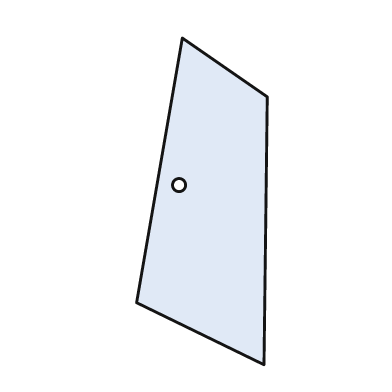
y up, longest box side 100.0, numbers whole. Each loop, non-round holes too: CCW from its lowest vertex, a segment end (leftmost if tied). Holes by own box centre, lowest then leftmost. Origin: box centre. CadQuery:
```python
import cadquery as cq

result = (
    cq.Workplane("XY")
    .moveTo(19.0, -50.0)
    .lineTo(20.0, 32.0)
    .lineTo(-6.0, 50.0)
    .lineTo(-20.0, -31.0)
    .close()
    .moveTo(-7.0, 5.0)
    .circle(2.0)
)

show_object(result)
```